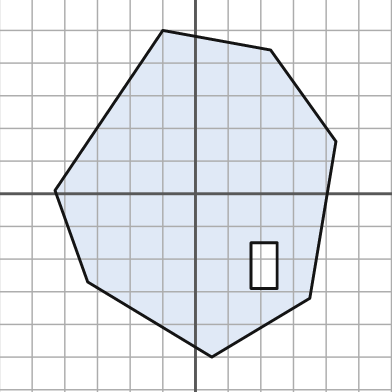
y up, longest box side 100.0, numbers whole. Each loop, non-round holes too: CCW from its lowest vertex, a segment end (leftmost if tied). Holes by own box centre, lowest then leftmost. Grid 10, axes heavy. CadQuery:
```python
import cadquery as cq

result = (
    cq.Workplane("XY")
    .moveTo(5.0, -50.0)
    .lineTo(35.0, -32.0)
    .lineTo(43.0, 16.0)
    .lineTo(23.0, 44.0)
    .lineTo(-10.0, 50.0)
    .lineTo(-43.0, 1.0)
    .lineTo(-33.0, -27.0)
    .close()
    .moveTo(17.0, -29.0)
    .lineTo(25.0, -29.0)
    .lineTo(25.0, -15.0)
    .lineTo(17.0, -15.0)
    .close()
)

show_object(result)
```